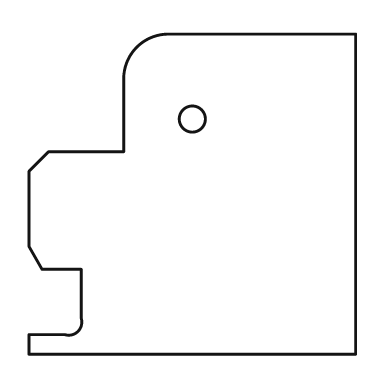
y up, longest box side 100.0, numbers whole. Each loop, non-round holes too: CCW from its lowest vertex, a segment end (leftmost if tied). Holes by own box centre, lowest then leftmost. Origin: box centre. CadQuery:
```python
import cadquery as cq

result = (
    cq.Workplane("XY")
    .moveTo(-50.0, -49.0)
    .lineTo(50.0, -49.0)
    .lineTo(50.0, 49.0)
    .lineTo(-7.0, 49.0)
    .threePointArc((-17.0, 45.0), (-21.0, 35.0))
    .lineTo(-21.0, 13.0)
    .lineTo(-44.0, 13.0)
    .lineTo(-50.0, 7.0)
    .lineTo(-50.0, -16.0)
    .lineTo(-46.0, -23.0)
    .lineTo(-34.0, -23.0)
    .lineTo(-34.0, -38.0)
    .threePointArc((-35.0, -42.0), (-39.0, -43.0))
    .lineTo(-50.0, -43.0)
    .close()
    .moveTo(0.0, 23.0)
    .circle(4.0)
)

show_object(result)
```